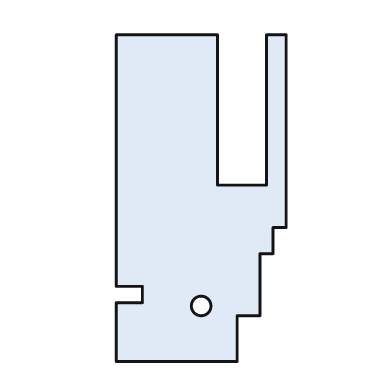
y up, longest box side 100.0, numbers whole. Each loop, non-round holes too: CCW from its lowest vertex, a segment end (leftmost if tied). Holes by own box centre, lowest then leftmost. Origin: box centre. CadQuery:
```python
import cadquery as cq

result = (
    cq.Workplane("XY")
    .moveTo(-26.0, -50.0)
    .lineTo(11.0, -50.0)
    .lineTo(11.0, -36.0)
    .lineTo(18.0, -36.0)
    .lineTo(18.0, -17.0)
    .lineTo(22.0, -17.0)
    .lineTo(22.0, -9.0)
    .lineTo(26.0, -9.0)
    .lineTo(26.0, 50.0)
    .lineTo(20.0, 50.0)
    .lineTo(20.0, 4.0)
    .lineTo(5.0, 4.0)
    .lineTo(5.0, 50.0)
    .lineTo(-26.0, 50.0)
    .lineTo(-26.0, -27.0)
    .lineTo(-18.0, -27.0)
    .lineTo(-18.0, -32.0)
    .lineTo(-26.0, -32.0)
    .close()
    .moveTo(0.0, -33.0)
    .circle(3.0)
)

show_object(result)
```